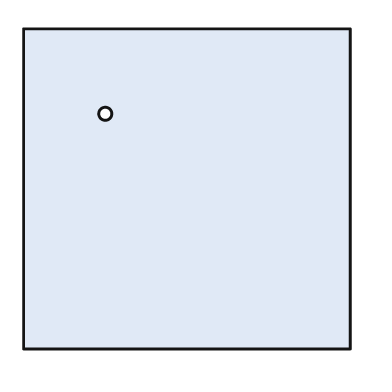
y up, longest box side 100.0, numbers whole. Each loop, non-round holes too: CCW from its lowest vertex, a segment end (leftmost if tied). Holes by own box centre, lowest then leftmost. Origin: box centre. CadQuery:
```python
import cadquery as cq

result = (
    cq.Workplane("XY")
    .moveTo(-50.0, -49.0)
    .lineTo(50.0, -49.0)
    .lineTo(50.0, 49.0)
    .lineTo(-50.0, 49.0)
    .close()
    .moveTo(-25.0, 23.0)
    .circle(2.0)
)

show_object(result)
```